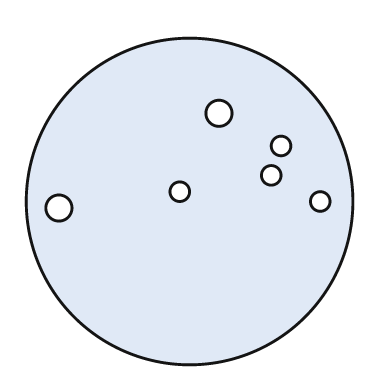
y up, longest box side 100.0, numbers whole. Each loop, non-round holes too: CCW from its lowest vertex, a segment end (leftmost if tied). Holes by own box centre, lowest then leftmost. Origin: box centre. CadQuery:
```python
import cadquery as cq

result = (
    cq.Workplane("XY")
    .moveTo(0.0, 0.0)
    .circle(50.0)
    .moveTo(-40.0, -2.0)
    .circle(4.0)
    .moveTo(40.0, 0.0)
    .circle(3.0)
    .moveTo(-3.0, 3.0)
    .circle(3.0)
    .moveTo(25.0, 8.0)
    .circle(3.0)
    .moveTo(28.0, 17.0)
    .circle(3.0)
    .moveTo(9.0, 27.0)
    .circle(4.0)
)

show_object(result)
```